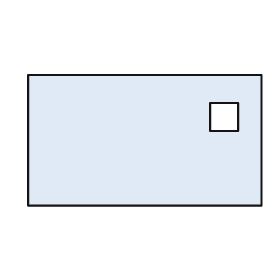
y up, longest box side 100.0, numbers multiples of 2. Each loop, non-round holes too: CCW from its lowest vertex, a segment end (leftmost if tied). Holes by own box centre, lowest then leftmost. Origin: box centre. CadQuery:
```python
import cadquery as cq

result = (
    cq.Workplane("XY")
    .moveTo(-50.0, -28.0)
    .lineTo(50.0, -28.0)
    .lineTo(50.0, 28.0)
    .lineTo(-50.0, 28.0)
    .close()
    .moveTo(28.0, 4.0)
    .lineTo(40.0, 4.0)
    .lineTo(40.0, 16.0)
    .lineTo(28.0, 16.0)
    .close()
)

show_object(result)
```